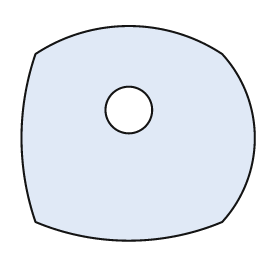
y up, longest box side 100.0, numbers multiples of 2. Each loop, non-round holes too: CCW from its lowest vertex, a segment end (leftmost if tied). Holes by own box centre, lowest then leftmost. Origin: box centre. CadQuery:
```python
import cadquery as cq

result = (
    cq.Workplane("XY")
    .moveTo(-44.0, -38.0)
    .threePointArc((-4.0, -46.0), (36.0, -38.0))
    .threePointArc((50.0, -2.0), (36.0, 34.0))
    .threePointArc((-4.0, 46.0), (-44.0, 34.0))
    .threePointArc((-50.0, -2.0), (-44.0, -38.0))
    .close()
    .moveTo(-4.0, 10.0)
    .circle(10.0)
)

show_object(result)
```